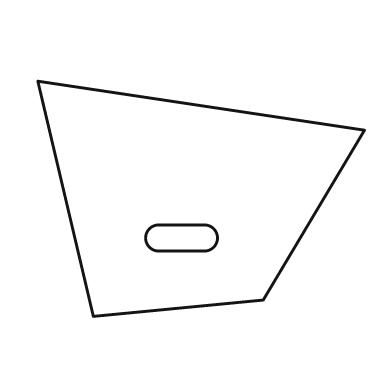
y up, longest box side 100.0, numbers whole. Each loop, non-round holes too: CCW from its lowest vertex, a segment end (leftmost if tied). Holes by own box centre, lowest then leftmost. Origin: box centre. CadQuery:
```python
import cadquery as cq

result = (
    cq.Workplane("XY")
    .moveTo(-33.0, -36.0)
    .lineTo(19.0, -31.0)
    .lineTo(50.0, 21.0)
    .lineTo(-50.0, 36.0)
    .close()
    .moveTo(-13.0, -16.0)
    .lineTo(1.0, -16.0)
    .threePointArc((5.0, -12.0), (1.0, -8.0))
    .lineTo(-13.0, -8.0)
    .threePointArc((-17.0, -12.0), (-13.0, -16.0))
    .close()
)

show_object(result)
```